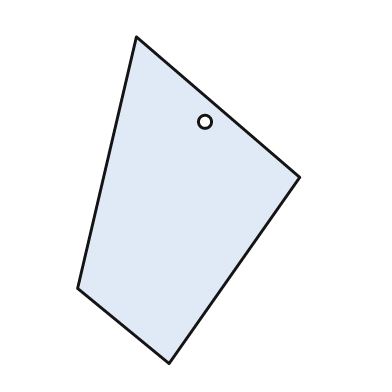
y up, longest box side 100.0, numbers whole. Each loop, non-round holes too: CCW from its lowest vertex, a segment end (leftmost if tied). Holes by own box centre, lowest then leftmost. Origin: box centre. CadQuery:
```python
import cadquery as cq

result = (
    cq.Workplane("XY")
    .moveTo(-6.0, -50.0)
    .lineTo(34.0, 7.0)
    .lineTo(-16.0, 50.0)
    .lineTo(-34.0, -27.0)
    .close()
    .moveTo(5.0, 24.0)
    .circle(2.0)
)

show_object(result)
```